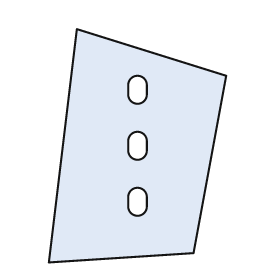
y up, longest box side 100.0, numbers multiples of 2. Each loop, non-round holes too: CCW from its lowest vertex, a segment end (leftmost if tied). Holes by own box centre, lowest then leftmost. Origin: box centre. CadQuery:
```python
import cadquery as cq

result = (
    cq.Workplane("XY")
    .moveTo(-38.0, -50.0)
    .lineTo(24.0, -46.0)
    .lineTo(38.0, 30.0)
    .lineTo(-26.0, 50.0)
    .close()
    .moveTo(-4.0, -26.0)
    .threePointArc((0.0, -30.0), (4.0, -26.0))
    .lineTo(4.0, -22.0)
    .threePointArc((0.0, -18.0), (-4.0, -22.0))
    .close()
    .moveTo(-4.0, -2.0)
    .threePointArc((0.0, -6.0), (4.0, -2.0))
    .lineTo(4.0, 2.0)
    .threePointArc((0.0, 6.0), (-4.0, 2.0))
    .close()
    .moveTo(-4.0, 22.0)
    .threePointArc((0.0, 18.0), (4.0, 22.0))
    .lineTo(4.0, 26.0)
    .threePointArc((0.0, 30.0), (-4.0, 26.0))
    .close()
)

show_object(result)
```